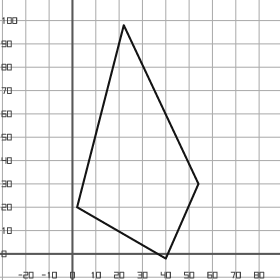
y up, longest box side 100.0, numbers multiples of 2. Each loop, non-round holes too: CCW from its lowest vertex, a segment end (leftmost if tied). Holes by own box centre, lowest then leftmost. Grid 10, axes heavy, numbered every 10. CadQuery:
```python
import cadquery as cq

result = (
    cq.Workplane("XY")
    .moveTo(40.0, -2.0)
    .lineTo(54.0, 30.0)
    .lineTo(22.0, 98.0)
    .lineTo(2.0, 20.0)
    .close()
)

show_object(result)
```